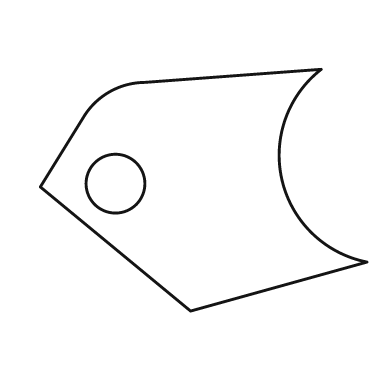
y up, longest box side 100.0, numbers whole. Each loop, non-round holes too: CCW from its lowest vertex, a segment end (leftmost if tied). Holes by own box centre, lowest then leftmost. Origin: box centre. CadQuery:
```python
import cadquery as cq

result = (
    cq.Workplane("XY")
    .moveTo(-4.0, -37.0)
    .lineTo(50.0, -22.0)
    .threePointArc((24.0, 3.0), (36.0, 37.0))
    .lineTo(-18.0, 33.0)
    .threePointArc((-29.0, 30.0), (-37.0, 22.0))
    .lineTo(-50.0, 1.0)
    .close()
    .moveTo(-27.0, 2.0)
    .circle(9.0)
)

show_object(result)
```